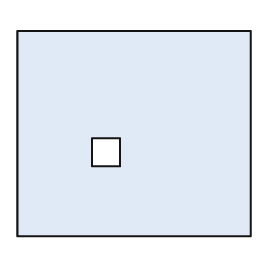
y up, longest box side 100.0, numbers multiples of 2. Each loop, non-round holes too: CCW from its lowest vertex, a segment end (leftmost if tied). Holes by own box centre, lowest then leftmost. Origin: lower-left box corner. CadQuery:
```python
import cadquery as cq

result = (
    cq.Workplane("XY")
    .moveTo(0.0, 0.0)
    .lineTo(100.0, 0.0)
    .lineTo(100.0, 88.0)
    .lineTo(0.0, 88.0)
    .close()
    .moveTo(32.0, 30.0)
    .lineTo(44.0, 30.0)
    .lineTo(44.0, 42.0)
    .lineTo(32.0, 42.0)
    .close()
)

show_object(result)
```